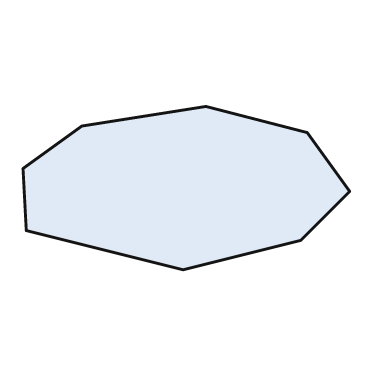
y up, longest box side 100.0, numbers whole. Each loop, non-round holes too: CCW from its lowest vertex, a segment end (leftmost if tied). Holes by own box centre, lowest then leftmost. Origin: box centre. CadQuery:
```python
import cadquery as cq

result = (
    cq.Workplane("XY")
    .moveTo(-1.0, -25.0)
    .lineTo(35.0, -16.0)
    .lineTo(50.0, -1.0)
    .lineTo(37.0, 17.0)
    .lineTo(6.0, 25.0)
    .lineTo(-32.0, 19.0)
    .lineTo(-50.0, 6.0)
    .lineTo(-49.0, -13.0)
    .close()
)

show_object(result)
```